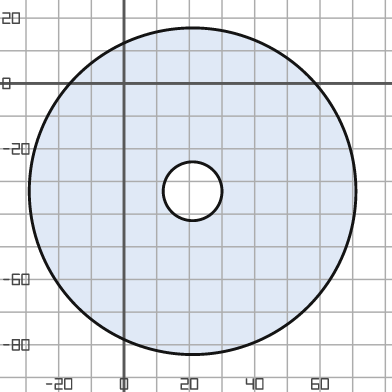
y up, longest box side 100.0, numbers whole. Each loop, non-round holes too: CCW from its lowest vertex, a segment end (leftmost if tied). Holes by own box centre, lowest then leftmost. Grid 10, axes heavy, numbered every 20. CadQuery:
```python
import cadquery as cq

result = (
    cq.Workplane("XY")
    .moveTo(21.0, -33.0)
    .circle(50.0)
    .moveTo(21.0, -33.0)
    .circle(9.0)
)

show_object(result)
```